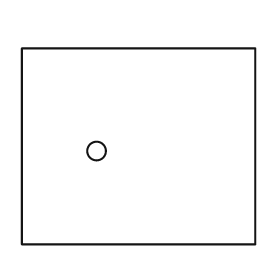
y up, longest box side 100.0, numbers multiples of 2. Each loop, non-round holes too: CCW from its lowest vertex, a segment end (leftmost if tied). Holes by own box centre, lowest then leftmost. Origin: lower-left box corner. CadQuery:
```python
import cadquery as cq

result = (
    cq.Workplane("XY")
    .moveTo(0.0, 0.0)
    .lineTo(100.0, 0.0)
    .lineTo(100.0, 84.0)
    .lineTo(0.0, 84.0)
    .close()
    .moveTo(32.0, 40.0)
    .circle(4.0)
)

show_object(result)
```